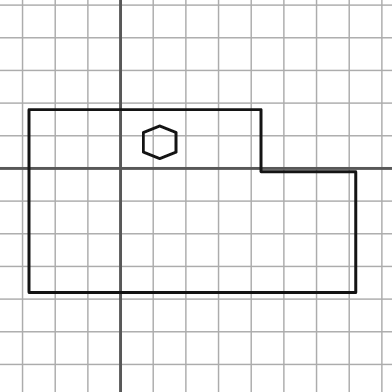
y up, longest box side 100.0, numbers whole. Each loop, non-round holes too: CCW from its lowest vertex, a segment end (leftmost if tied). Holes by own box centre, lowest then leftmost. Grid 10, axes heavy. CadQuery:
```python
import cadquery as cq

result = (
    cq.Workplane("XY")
    .moveTo(-28.0, -38.0)
    .lineTo(72.0, -38.0)
    .lineTo(72.0, -1.0)
    .lineTo(43.0, -1.0)
    .lineTo(43.0, 18.0)
    .lineTo(-28.0, 18.0)
    .close()
    .moveTo(12.0, 3.0)
    .lineTo(17.0, 5.0)
    .lineTo(17.0, 11.0)
    .lineTo(12.0, 13.0)
    .lineTo(7.0, 11.0)
    .lineTo(7.0, 5.0)
    .close()
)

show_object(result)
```